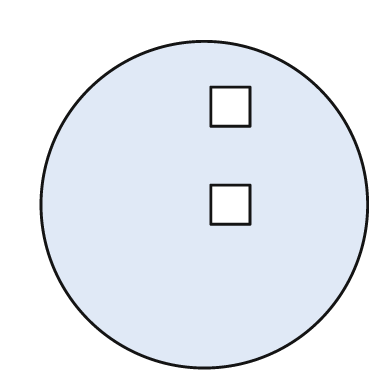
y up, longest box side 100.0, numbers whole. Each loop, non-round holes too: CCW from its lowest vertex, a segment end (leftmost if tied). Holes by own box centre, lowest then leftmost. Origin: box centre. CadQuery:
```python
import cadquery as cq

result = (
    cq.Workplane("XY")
    .moveTo(0.0, 0.0)
    .circle(50.0)
    .moveTo(2.0, -6.0)
    .lineTo(14.0, -6.0)
    .lineTo(14.0, 6.0)
    .lineTo(2.0, 6.0)
    .close()
    .moveTo(2.0, 24.0)
    .lineTo(14.0, 24.0)
    .lineTo(14.0, 36.0)
    .lineTo(2.0, 36.0)
    .close()
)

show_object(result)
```